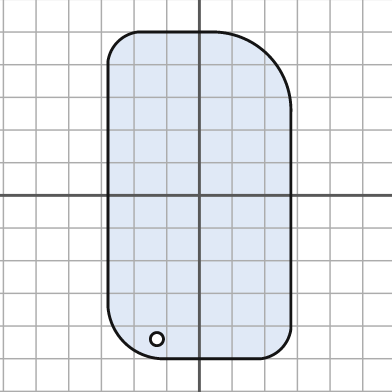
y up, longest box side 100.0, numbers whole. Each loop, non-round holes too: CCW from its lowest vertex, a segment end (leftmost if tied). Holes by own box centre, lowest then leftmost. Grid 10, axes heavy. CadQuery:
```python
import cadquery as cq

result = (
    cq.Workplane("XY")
    .moveTo(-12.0, -50.0)
    .lineTo(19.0, -50.0)
    .threePointArc((25.0, -47.0), (28.0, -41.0))
    .lineTo(28.0, 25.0)
    .threePointArc((21.0, 43.0), (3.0, 50.0))
    .lineTo(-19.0, 50.0)
    .threePointArc((-25.0, 47.0), (-28.0, 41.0))
    .lineTo(-28.0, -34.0)
    .threePointArc((-23.0, -45.0), (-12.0, -50.0))
    .close()
    .moveTo(-13.0, -44.0)
    .circle(2.0)
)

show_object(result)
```